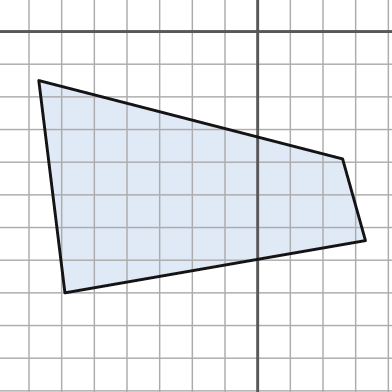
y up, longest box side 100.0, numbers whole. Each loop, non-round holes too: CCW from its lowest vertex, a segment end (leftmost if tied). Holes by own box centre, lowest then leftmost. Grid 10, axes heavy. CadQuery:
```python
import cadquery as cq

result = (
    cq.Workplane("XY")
    .moveTo(-59.0, -80.0)
    .lineTo(33.0, -64.0)
    .lineTo(26.0, -39.0)
    .lineTo(-67.0, -15.0)
    .close()
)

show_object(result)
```